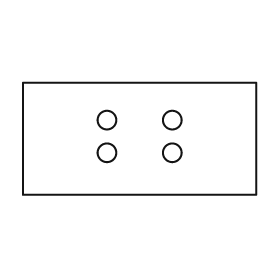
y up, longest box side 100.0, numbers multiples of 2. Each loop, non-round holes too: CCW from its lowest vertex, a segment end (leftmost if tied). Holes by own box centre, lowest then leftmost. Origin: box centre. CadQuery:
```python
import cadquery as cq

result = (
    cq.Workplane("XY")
    .moveTo(-50.0, -24.0)
    .lineTo(50.0, -24.0)
    .lineTo(50.0, 24.0)
    .lineTo(-50.0, 24.0)
    .close()
    .moveTo(-14.0, -6.0)
    .circle(4.0)
    .moveTo(14.0, -6.0)
    .circle(4.0)
    .moveTo(-14.0, 8.0)
    .circle(4.0)
    .moveTo(14.0, 8.0)
    .circle(4.0)
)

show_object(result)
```